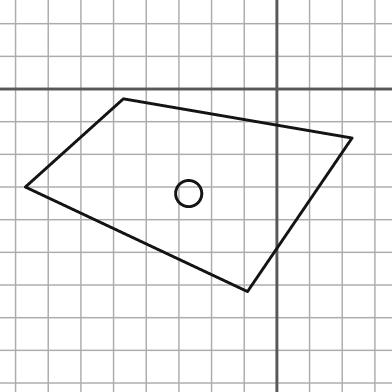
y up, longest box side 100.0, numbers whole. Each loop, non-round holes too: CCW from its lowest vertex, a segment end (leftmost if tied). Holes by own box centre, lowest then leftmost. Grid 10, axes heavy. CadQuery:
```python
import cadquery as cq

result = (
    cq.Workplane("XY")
    .moveTo(-9.0, -62.0)
    .lineTo(23.0, -15.0)
    .lineTo(-47.0, -3.0)
    .lineTo(-77.0, -30.0)
    .close()
    .moveTo(-27.0, -32.0)
    .circle(4.0)
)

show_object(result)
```